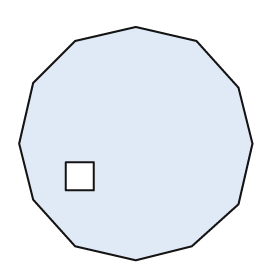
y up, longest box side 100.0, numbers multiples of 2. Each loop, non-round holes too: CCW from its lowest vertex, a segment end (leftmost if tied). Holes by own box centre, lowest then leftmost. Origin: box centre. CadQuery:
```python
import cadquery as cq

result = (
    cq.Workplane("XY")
    .moveTo(0.0, -50.0)
    .lineTo(24.0, -44.0)
    .lineTo(44.0, -26.0)
    .lineTo(50.0, 0.0)
    .lineTo(44.0, 24.0)
    .lineTo(26.0, 44.0)
    .lineTo(0.0, 50.0)
    .lineTo(-26.0, 44.0)
    .lineTo(-44.0, 26.0)
    .lineTo(-50.0, 0.0)
    .lineTo(-44.0, -24.0)
    .lineTo(-26.0, -44.0)
    .close()
    .moveTo(-30.0, -20.0)
    .lineTo(-18.0, -20.0)
    .lineTo(-18.0, -8.0)
    .lineTo(-30.0, -8.0)
    .close()
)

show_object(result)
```